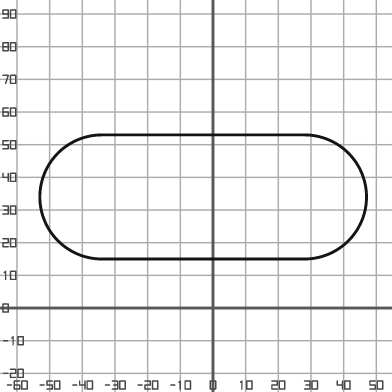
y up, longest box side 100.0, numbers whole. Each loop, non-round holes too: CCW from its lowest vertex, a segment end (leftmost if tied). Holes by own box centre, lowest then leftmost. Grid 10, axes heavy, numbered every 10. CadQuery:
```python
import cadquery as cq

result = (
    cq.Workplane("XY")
    .moveTo(-34.0, 15.0)
    .lineTo(28.0, 15.0)
    .threePointArc((47.0, 34.0), (28.0, 53.0))
    .lineTo(-34.0, 53.0)
    .threePointArc((-53.0, 34.0), (-34.0, 15.0))
    .close()
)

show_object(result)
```